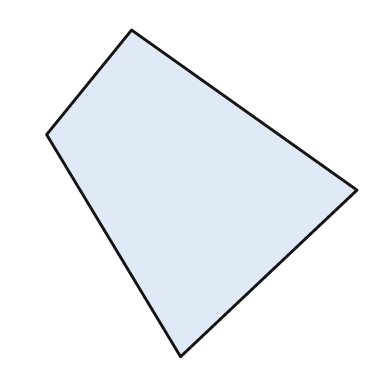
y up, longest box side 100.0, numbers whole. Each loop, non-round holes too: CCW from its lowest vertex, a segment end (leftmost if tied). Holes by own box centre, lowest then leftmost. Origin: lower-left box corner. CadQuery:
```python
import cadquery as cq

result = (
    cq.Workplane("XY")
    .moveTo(41.0, 0.0)
    .lineTo(95.0, 51.0)
    .lineTo(26.0, 100.0)
    .lineTo(0.0, 68.0)
    .close()
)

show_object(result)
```